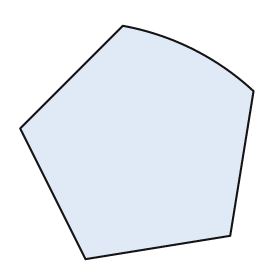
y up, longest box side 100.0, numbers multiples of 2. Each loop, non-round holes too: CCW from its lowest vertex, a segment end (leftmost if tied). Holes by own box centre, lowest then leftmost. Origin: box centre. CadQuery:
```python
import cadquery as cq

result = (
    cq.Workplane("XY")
    .moveTo(-22.0, -50.0)
    .lineTo(40.0, -40.0)
    .lineTo(50.0, 22.0)
    .threePointArc((24.0, 40.0), (-6.0, 50.0))
    .lineTo(-50.0, 6.0)
    .close()
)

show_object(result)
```